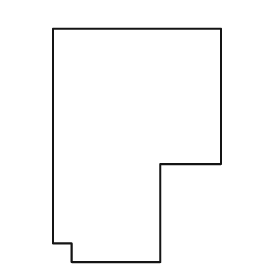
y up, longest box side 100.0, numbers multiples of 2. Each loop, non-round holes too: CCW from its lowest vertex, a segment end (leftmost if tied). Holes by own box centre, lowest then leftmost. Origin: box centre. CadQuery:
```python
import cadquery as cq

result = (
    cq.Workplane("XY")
    .moveTo(-28.0, -50.0)
    .lineTo(10.0, -50.0)
    .lineTo(10.0, -8.0)
    .lineTo(36.0, -8.0)
    .lineTo(36.0, 50.0)
    .lineTo(-36.0, 50.0)
    .lineTo(-36.0, -42.0)
    .lineTo(-28.0, -42.0)
    .close()
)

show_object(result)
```